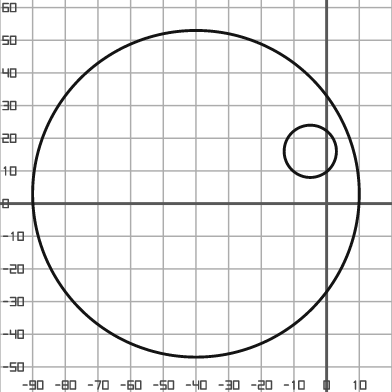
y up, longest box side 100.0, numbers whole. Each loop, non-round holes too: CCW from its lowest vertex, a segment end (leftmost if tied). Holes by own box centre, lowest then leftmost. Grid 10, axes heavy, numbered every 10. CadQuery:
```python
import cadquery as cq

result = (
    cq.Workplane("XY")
    .moveTo(-40.0, 3.0)
    .circle(50.0)
    .moveTo(-5.0, 16.0)
    .circle(8.0)
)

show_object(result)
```